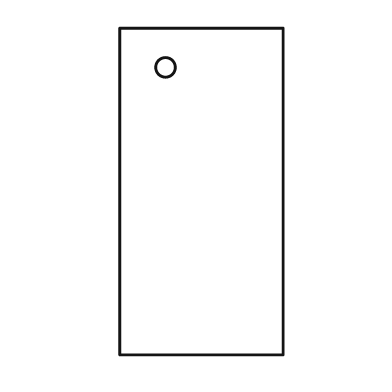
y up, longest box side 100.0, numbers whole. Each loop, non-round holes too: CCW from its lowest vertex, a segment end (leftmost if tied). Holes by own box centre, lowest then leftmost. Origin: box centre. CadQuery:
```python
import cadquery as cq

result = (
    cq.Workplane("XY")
    .moveTo(-25.0, -50.0)
    .lineTo(25.0, -50.0)
    .lineTo(25.0, 50.0)
    .lineTo(-25.0, 50.0)
    .close()
    .moveTo(-11.0, 38.0)
    .circle(3.0)
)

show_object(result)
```